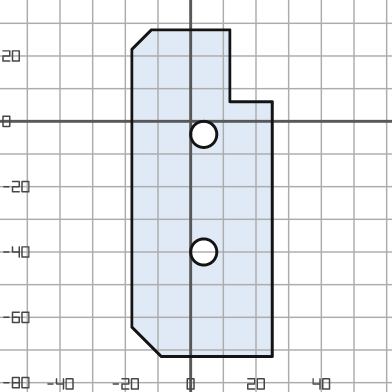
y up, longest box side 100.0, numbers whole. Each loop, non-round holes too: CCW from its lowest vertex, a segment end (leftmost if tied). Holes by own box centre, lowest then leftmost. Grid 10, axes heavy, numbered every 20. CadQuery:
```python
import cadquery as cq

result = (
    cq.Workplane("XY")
    .moveTo(-9.0, -72.0)
    .lineTo(25.0, -72.0)
    .lineTo(25.0, 6.0)
    .lineTo(12.0, 6.0)
    .lineTo(12.0, 28.0)
    .lineTo(-12.0, 28.0)
    .lineTo(-18.0, 22.0)
    .lineTo(-18.0, -63.0)
    .close()
    .moveTo(4.0, -40.0)
    .circle(4.0)
    .moveTo(4.0, -4.0)
    .circle(4.0)
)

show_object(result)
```